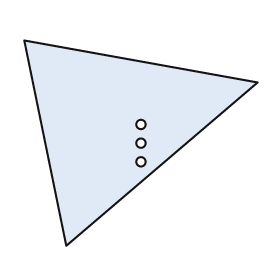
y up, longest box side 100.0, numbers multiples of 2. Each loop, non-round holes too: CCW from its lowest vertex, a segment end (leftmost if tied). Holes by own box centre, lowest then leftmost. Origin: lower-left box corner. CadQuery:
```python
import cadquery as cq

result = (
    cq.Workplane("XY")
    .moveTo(18.0, 0.0)
    .lineTo(100.0, 70.0)
    .lineTo(0.0, 88.0)
    .close()
    .moveTo(50.0, 36.0)
    .circle(2.0)
    .moveTo(50.0, 44.0)
    .circle(2.0)
    .moveTo(50.0, 52.0)
    .circle(2.0)
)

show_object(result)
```